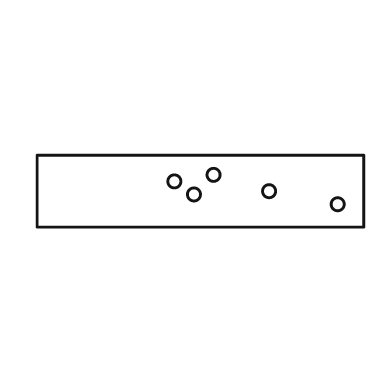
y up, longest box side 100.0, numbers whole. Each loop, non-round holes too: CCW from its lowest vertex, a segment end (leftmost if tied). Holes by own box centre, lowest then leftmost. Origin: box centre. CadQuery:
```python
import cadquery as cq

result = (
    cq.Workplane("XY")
    .moveTo(-50.0, -11.0)
    .lineTo(50.0, -11.0)
    .lineTo(50.0, 11.0)
    .lineTo(-50.0, 11.0)
    .close()
    .moveTo(42.0, -4.0)
    .circle(2.0)
    .moveTo(-2.0, -1.0)
    .circle(2.0)
    .moveTo(21.0, 0.0)
    .circle(2.0)
    .moveTo(-8.0, 3.0)
    .circle(2.0)
    .moveTo(4.0, 5.0)
    .circle(2.0)
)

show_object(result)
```